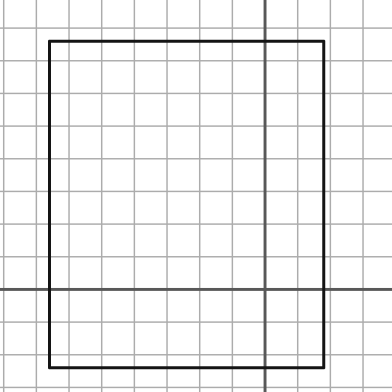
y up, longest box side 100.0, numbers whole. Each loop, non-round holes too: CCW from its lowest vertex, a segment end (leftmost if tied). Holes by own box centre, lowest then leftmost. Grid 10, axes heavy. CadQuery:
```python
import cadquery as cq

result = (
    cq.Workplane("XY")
    .moveTo(-66.0, -24.0)
    .lineTo(18.0, -24.0)
    .lineTo(18.0, 76.0)
    .lineTo(-66.0, 76.0)
    .close()
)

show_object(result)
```